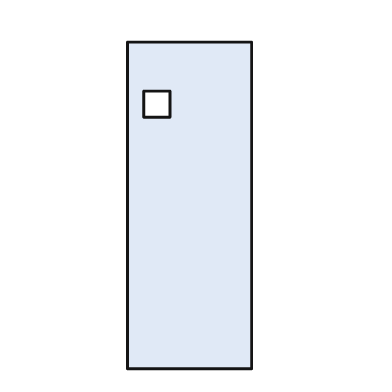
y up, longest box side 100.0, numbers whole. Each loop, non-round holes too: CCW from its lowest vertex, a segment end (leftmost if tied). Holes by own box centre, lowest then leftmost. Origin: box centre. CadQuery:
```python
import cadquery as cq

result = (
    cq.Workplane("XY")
    .moveTo(-19.0, -50.0)
    .lineTo(19.0, -50.0)
    .lineTo(19.0, 50.0)
    .lineTo(-19.0, 50.0)
    .close()
    .moveTo(-14.0, 27.0)
    .lineTo(-6.0, 27.0)
    .lineTo(-6.0, 35.0)
    .lineTo(-14.0, 35.0)
    .close()
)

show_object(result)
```